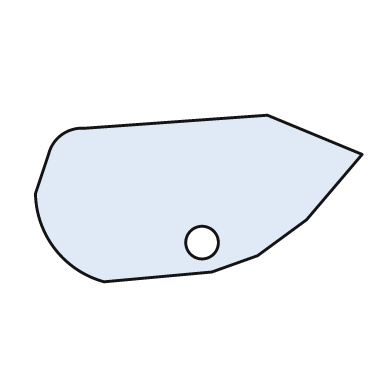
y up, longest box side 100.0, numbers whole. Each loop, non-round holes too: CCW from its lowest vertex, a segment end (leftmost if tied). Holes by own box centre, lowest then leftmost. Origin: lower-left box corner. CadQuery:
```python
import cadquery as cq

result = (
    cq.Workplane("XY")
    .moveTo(21.0, 0.0)
    .lineTo(54.0, 3.0)
    .lineTo(68.0, 8.0)
    .lineTo(83.0, 19.0)
    .lineTo(100.0, 39.0)
    .lineTo(71.0, 51.0)
    .lineTo(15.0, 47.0)
    .threePointArc((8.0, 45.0), (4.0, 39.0))
    .lineTo(0.0, 27.0)
    .threePointArc((6.0, 10.0), (21.0, 0.0))
    .close()
    .moveTo(51.0, 12.0)
    .circle(5.0)
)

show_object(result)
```